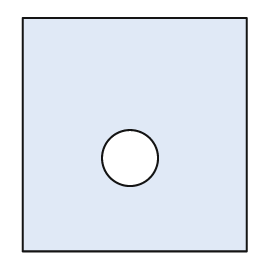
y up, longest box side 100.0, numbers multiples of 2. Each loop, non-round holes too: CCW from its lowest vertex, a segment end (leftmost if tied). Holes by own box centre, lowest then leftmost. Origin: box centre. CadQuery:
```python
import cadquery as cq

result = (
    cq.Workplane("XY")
    .moveTo(-48.0, -50.0)
    .lineTo(48.0, -50.0)
    .lineTo(48.0, 50.0)
    .lineTo(-48.0, 50.0)
    .close()
    .moveTo(-2.0, -10.0)
    .circle(12.0)
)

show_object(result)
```